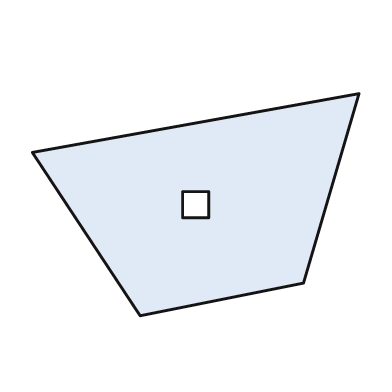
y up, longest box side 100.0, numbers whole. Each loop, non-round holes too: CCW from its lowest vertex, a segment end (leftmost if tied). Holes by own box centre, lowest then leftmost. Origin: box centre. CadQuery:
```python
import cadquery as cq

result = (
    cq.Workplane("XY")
    .moveTo(-17.0, -34.0)
    .lineTo(33.0, -24.0)
    .lineTo(50.0, 34.0)
    .lineTo(-50.0, 16.0)
    .close()
    .moveTo(-4.0, -4.0)
    .lineTo(4.0, -4.0)
    .lineTo(4.0, 4.0)
    .lineTo(-4.0, 4.0)
    .close()
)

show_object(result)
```